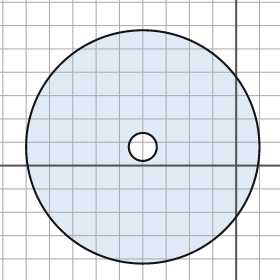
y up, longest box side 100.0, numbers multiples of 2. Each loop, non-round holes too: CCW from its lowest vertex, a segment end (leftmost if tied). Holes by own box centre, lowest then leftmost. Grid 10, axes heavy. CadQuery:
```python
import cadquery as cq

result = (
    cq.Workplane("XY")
    .moveTo(-40.0, 8.0)
    .circle(50.0)
    .moveTo(-40.0, 8.0)
    .circle(6.0)
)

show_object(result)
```